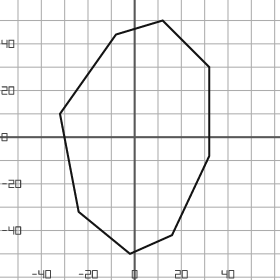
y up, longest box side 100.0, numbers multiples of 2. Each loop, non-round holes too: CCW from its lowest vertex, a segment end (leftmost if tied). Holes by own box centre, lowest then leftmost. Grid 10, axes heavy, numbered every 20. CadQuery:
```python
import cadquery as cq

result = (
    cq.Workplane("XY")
    .moveTo(-2.0, -50.0)
    .lineTo(16.0, -42.0)
    .lineTo(32.0, -8.0)
    .lineTo(32.0, 30.0)
    .lineTo(12.0, 50.0)
    .lineTo(-8.0, 44.0)
    .lineTo(-32.0, 10.0)
    .lineTo(-24.0, -32.0)
    .close()
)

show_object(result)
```